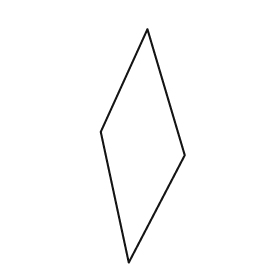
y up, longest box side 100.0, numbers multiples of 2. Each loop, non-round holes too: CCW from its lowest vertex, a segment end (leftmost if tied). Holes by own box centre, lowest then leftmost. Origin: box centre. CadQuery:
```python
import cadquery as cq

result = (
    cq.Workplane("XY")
    .moveTo(-6.0, -50.0)
    .lineTo(18.0, -4.0)
    .lineTo(2.0, 50.0)
    .lineTo(-18.0, 6.0)
    .close()
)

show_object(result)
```